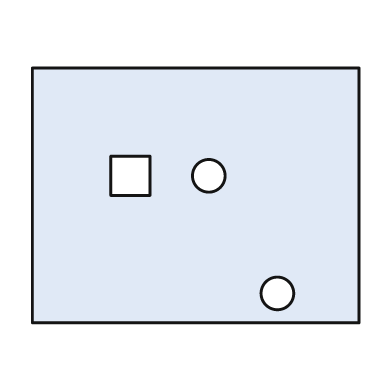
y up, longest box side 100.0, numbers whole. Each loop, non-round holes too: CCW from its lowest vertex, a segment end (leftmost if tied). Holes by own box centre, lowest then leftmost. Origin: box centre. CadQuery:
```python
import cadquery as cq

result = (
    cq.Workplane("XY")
    .moveTo(-50.0, -39.0)
    .lineTo(50.0, -39.0)
    .lineTo(50.0, 39.0)
    .lineTo(-50.0, 39.0)
    .close()
    .moveTo(25.0, -30.0)
    .circle(5.0)
    .moveTo(-26.0, 0.0)
    .lineTo(-14.0, 0.0)
    .lineTo(-14.0, 12.0)
    .lineTo(-26.0, 12.0)
    .close()
    .moveTo(4.0, 6.0)
    .circle(5.0)
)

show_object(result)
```